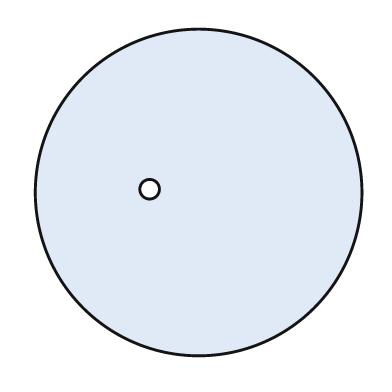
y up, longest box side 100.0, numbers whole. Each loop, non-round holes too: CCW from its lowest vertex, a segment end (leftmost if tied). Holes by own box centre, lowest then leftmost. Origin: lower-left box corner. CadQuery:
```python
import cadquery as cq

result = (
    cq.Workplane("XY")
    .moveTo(50.0, 50.0)
    .circle(50.0)
    .moveTo(35.0, 51.0)
    .circle(3.0)
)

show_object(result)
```